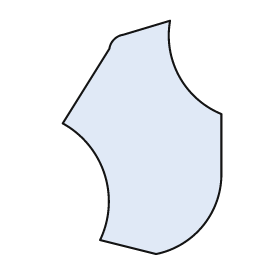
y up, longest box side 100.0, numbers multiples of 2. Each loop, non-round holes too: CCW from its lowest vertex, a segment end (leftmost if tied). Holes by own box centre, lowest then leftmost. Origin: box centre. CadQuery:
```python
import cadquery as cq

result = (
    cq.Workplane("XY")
    .moveTo(6.0, -50.0)
    .threePointArc((26.0, -38.0), (34.0, -16.0))
    .lineTo(34.0, 10.0)
    .threePointArc((16.0, 26.0), (12.0, 50.0))
    .lineTo(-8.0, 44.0)
    .threePointArc((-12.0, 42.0), (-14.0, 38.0))
    .lineTo(-34.0, 6.0)
    .threePointArc((-16.0, -16.0), (-18.0, -44.0))
    .close()
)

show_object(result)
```